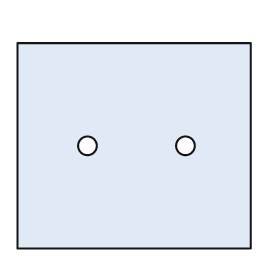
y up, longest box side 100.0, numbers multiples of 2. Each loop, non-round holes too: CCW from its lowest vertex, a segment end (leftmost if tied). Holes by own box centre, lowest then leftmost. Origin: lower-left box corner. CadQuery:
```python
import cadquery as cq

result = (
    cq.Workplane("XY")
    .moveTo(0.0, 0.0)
    .lineTo(100.0, 0.0)
    .lineTo(100.0, 88.0)
    .lineTo(0.0, 88.0)
    .close()
    .moveTo(30.0, 44.0)
    .circle(4.0)
    .moveTo(72.0, 44.0)
    .circle(4.0)
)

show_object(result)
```